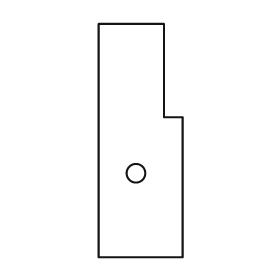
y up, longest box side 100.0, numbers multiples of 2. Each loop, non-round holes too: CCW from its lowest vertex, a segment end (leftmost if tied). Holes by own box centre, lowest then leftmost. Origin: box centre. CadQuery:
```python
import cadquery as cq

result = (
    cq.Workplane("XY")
    .moveTo(-18.0, -50.0)
    .lineTo(18.0, -50.0)
    .lineTo(18.0, 10.0)
    .lineTo(10.0, 10.0)
    .lineTo(10.0, 50.0)
    .lineTo(-18.0, 50.0)
    .close()
    .moveTo(-2.0, -14.0)
    .circle(4.0)
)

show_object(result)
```